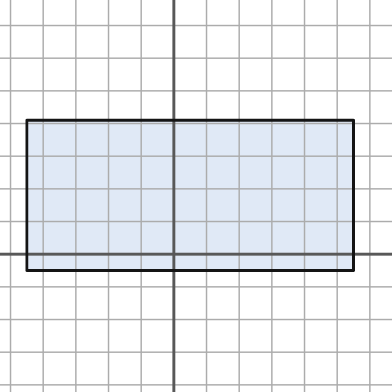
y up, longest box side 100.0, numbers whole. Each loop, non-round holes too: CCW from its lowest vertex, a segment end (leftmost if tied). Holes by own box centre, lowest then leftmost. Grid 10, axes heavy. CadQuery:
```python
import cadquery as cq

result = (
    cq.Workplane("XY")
    .moveTo(-45.0, -5.0)
    .lineTo(55.0, -5.0)
    .lineTo(55.0, 41.0)
    .lineTo(-45.0, 41.0)
    .close()
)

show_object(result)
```